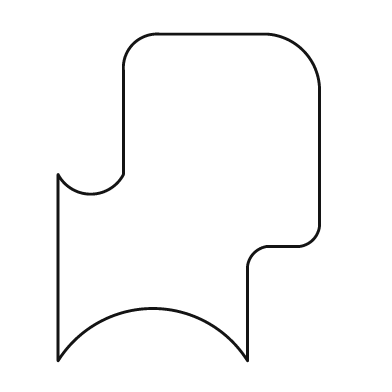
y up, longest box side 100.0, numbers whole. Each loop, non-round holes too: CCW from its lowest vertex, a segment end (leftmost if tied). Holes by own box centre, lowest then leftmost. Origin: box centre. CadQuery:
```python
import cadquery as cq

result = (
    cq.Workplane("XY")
    .moveTo(-40.0, -50.0)
    .threePointArc((-11.0, -34.0), (18.0, -50.0))
    .lineTo(18.0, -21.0)
    .threePointArc((20.0, -17.0), (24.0, -15.0))
    .lineTo(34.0, -15.0)
    .threePointArc((38.0, -13.0), (40.0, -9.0))
    .lineTo(40.0, 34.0)
    .threePointArc((35.0, 45.0), (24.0, 50.0))
    .lineTo(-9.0, 50.0)
    .threePointArc((-17.0, 47.0), (-20.0, 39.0))
    .lineTo(-20.0, 7.0)
    .threePointArc((-30.0, 1.0), (-40.0, 7.0))
    .close()
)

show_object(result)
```